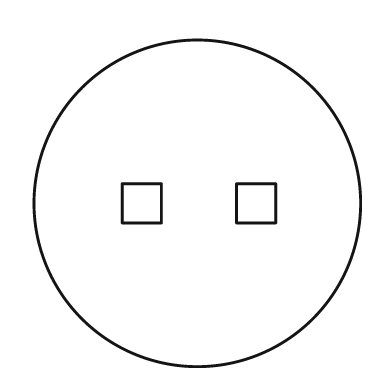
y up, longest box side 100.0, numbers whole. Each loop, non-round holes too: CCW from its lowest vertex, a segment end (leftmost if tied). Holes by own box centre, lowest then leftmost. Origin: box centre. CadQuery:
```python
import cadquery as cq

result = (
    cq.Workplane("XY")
    .moveTo(0.0, 0.0)
    .circle(50.0)
    .moveTo(-23.0, -6.0)
    .lineTo(-11.0, -6.0)
    .lineTo(-11.0, 6.0)
    .lineTo(-23.0, 6.0)
    .close()
    .moveTo(12.0, -6.0)
    .lineTo(24.0, -6.0)
    .lineTo(24.0, 6.0)
    .lineTo(12.0, 6.0)
    .close()
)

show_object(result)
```